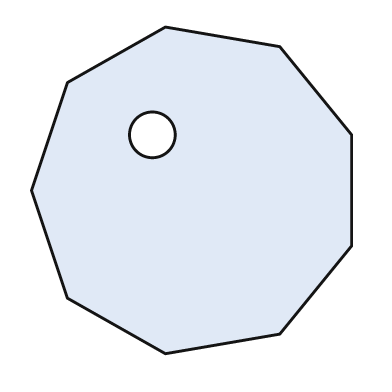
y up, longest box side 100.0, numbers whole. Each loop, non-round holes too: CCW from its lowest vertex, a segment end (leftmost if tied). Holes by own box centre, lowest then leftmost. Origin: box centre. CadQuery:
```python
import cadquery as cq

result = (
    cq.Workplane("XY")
    .moveTo(-8.0, -50.0)
    .lineTo(27.0, -44.0)
    .lineTo(49.0, -17.0)
    .lineTo(49.0, 17.0)
    .lineTo(27.0, 44.0)
    .lineTo(-8.0, 50.0)
    .lineTo(-38.0, 33.0)
    .lineTo(-49.0, 0.0)
    .lineTo(-38.0, -33.0)
    .close()
    .moveTo(-12.0, 17.0)
    .circle(7.0)
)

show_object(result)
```